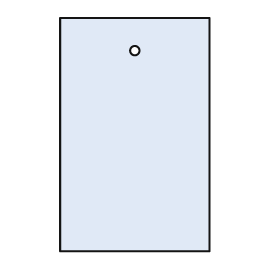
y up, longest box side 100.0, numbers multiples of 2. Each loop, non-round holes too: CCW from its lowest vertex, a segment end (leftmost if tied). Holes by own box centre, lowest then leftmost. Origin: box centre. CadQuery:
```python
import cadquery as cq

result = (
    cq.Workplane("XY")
    .moveTo(-32.0, -50.0)
    .lineTo(32.0, -50.0)
    .lineTo(32.0, 50.0)
    .lineTo(-32.0, 50.0)
    .close()
    .moveTo(0.0, 36.0)
    .circle(2.0)
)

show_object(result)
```